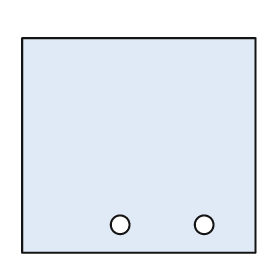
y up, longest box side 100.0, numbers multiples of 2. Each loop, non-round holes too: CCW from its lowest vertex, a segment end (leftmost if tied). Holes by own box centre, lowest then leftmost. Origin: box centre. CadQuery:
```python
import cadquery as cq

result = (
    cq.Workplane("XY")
    .moveTo(-50.0, -46.0)
    .lineTo(50.0, -46.0)
    .lineTo(50.0, 46.0)
    .lineTo(-50.0, 46.0)
    .close()
    .moveTo(-8.0, -34.0)
    .circle(4.0)
    .moveTo(28.0, -34.0)
    .circle(4.0)
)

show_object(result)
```